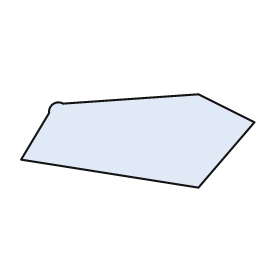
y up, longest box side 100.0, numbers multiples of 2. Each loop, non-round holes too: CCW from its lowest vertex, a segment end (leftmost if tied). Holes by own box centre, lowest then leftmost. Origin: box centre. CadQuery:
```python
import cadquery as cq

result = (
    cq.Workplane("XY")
    .moveTo(26.0, -20.0)
    .lineTo(50.0, 8.0)
    .lineTo(26.0, 20.0)
    .lineTo(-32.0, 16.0)
    .threePointArc((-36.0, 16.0), (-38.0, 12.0))
    .lineTo(-50.0, -8.0)
    .close()
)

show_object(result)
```